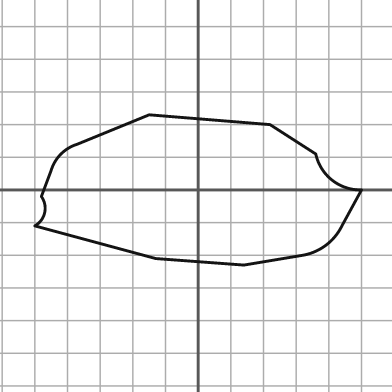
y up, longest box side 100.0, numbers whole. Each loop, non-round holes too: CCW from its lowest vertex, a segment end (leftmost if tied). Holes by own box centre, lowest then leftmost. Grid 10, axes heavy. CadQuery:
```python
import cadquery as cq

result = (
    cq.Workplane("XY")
    .moveTo(14.0, -23.0)
    .lineTo(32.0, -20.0)
    .threePointArc((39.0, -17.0), (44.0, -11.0))
    .lineTo(50.0, 0.0)
    .threePointArc((41.0, 3.0), (36.0, 11.0))
    .lineTo(22.0, 20.0)
    .lineTo(-15.0, 23.0)
    .lineTo(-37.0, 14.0)
    .threePointArc((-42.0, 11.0), (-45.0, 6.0))
    .lineTo(-48.0, -2.0)
    .threePointArc((-47.0, -7.0), (-50.0, -11.0))
    .lineTo(-13.0, -21.0)
    .close()
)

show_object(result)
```